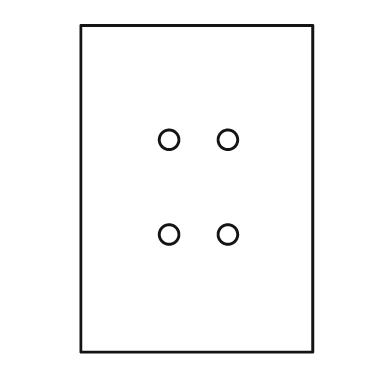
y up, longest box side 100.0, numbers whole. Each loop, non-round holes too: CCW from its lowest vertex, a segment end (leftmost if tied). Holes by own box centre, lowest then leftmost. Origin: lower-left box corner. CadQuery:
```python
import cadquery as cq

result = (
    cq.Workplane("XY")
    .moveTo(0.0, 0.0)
    .lineTo(71.0, 0.0)
    .lineTo(71.0, 100.0)
    .lineTo(0.0, 100.0)
    .close()
    .moveTo(27.0, 36.0)
    .circle(3.0)
    .moveTo(45.0, 36.0)
    .circle(3.0)
    .moveTo(27.0, 65.0)
    .circle(3.0)
    .moveTo(45.0, 65.0)
    .circle(3.0)
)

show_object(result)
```